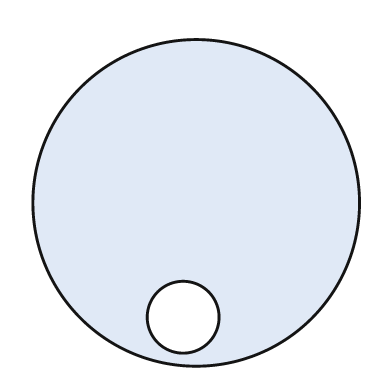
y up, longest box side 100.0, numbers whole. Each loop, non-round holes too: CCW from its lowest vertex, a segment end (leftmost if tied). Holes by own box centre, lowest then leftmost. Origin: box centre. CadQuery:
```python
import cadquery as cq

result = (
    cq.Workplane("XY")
    .moveTo(0.0, 0.0)
    .circle(50.0)
    .moveTo(-4.0, -35.0)
    .circle(11.0)
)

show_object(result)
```